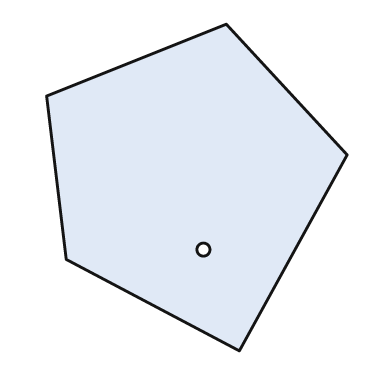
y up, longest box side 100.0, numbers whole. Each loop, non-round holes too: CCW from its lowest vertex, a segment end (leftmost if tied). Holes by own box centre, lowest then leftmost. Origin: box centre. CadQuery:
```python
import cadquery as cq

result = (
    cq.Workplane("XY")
    .moveTo(13.0, -50.0)
    .lineTo(46.0, 10.0)
    .lineTo(9.0, 50.0)
    .lineTo(-46.0, 28.0)
    .lineTo(-40.0, -22.0)
    .close()
    .moveTo(2.0, -19.0)
    .circle(2.0)
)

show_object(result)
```